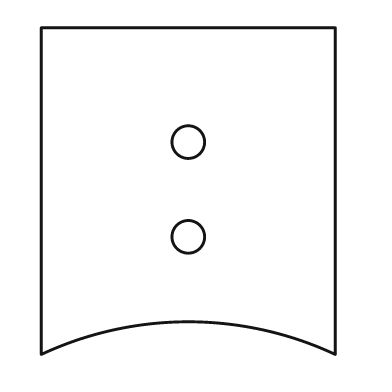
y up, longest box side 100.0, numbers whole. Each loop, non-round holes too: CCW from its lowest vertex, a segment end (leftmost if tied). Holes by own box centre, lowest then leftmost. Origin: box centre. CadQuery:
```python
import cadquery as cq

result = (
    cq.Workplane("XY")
    .moveTo(-45.0, -50.0)
    .threePointArc((0.0, -40.0), (45.0, -50.0))
    .lineTo(45.0, 50.0)
    .lineTo(-45.0, 50.0)
    .close()
    .moveTo(0.0, -14.0)
    .circle(5.0)
    .moveTo(0.0, 15.0)
    .circle(5.0)
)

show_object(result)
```